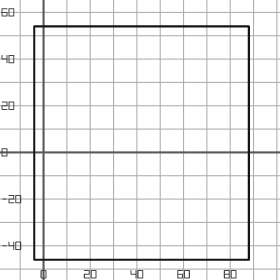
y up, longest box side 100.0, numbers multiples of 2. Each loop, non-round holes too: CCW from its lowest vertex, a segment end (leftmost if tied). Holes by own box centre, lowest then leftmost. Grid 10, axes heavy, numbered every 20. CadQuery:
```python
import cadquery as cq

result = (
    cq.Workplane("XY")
    .moveTo(-4.0, -46.0)
    .lineTo(88.0, -46.0)
    .lineTo(88.0, 54.0)
    .lineTo(-4.0, 54.0)
    .close()
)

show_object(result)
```